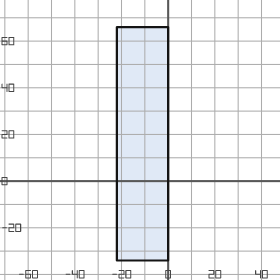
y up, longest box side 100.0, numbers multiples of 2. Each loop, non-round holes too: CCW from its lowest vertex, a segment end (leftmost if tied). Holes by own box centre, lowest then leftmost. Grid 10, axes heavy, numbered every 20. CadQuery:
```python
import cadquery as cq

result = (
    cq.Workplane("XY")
    .moveTo(-22.0, -34.0)
    .lineTo(0.0, -34.0)
    .lineTo(0.0, 66.0)
    .lineTo(-22.0, 66.0)
    .close()
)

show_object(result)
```